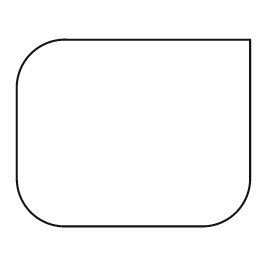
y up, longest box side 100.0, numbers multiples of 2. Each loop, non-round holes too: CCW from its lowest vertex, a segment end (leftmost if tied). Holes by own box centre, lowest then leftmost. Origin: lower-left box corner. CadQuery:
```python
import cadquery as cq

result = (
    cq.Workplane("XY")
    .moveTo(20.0, 0.0)
    .lineTo(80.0, 0.0)
    .threePointArc((94.0, 6.0), (100.0, 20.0))
    .lineTo(100.0, 80.0)
    .lineTo(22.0, 80.0)
    .threePointArc((6.0, 74.0), (0.0, 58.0))
    .lineTo(0.0, 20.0)
    .threePointArc((6.0, 6.0), (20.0, 0.0))
    .close()
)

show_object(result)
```